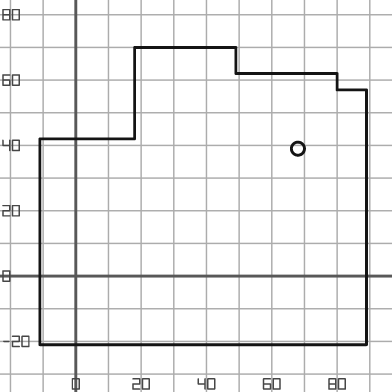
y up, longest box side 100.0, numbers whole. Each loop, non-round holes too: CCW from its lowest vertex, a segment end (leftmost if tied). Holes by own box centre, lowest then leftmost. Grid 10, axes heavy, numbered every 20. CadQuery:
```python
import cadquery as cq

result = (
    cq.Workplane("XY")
    .moveTo(-11.0, -21.0)
    .lineTo(89.0, -21.0)
    .lineTo(89.0, 57.0)
    .lineTo(80.0, 57.0)
    .lineTo(80.0, 62.0)
    .lineTo(49.0, 62.0)
    .lineTo(49.0, 70.0)
    .lineTo(18.0, 70.0)
    .lineTo(18.0, 42.0)
    .lineTo(-11.0, 42.0)
    .close()
    .moveTo(68.0, 39.0)
    .circle(2.0)
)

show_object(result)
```